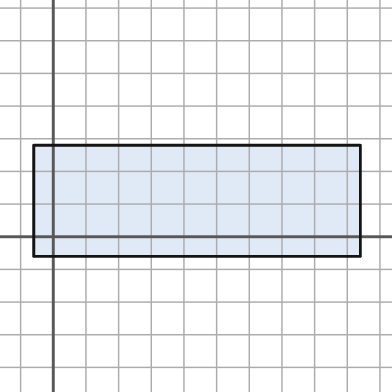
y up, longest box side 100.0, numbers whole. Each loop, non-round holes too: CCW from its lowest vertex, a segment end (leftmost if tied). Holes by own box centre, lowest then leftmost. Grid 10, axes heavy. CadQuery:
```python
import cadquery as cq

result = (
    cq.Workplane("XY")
    .moveTo(-6.0, -6.0)
    .lineTo(94.0, -6.0)
    .lineTo(94.0, 28.0)
    .lineTo(-6.0, 28.0)
    .close()
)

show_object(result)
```